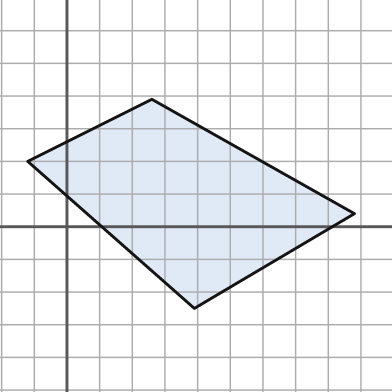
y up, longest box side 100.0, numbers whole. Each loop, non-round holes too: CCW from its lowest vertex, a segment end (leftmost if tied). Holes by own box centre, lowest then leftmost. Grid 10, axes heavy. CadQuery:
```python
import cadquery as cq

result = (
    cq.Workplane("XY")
    .moveTo(39.0, -25.0)
    .lineTo(88.0, 4.0)
    .lineTo(26.0, 39.0)
    .lineTo(-12.0, 20.0)
    .close()
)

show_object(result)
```